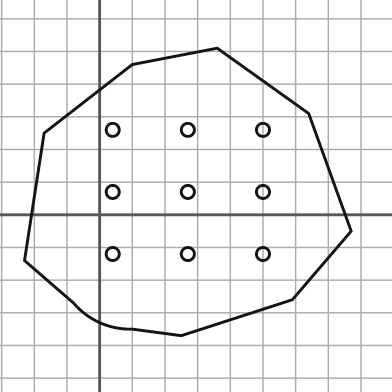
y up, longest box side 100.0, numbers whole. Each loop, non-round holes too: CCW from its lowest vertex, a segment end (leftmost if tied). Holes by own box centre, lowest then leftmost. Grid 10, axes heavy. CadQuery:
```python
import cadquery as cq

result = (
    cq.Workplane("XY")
    .moveTo(25.0, -37.0)
    .lineTo(59.0, -26.0)
    .lineTo(77.0, -5.0)
    .lineTo(64.0, 31.0)
    .lineTo(36.0, 51.0)
    .lineTo(10.0, 46.0)
    .lineTo(-17.0, 25.0)
    .lineTo(-23.0, -14.0)
    .lineTo(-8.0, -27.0)
    .threePointArc((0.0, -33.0), (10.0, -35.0))
    .close()
    .moveTo(4.0, -12.0)
    .circle(2.0)
    .moveTo(27.0, -12.0)
    .circle(2.0)
    .moveTo(50.0, -12.0)
    .circle(2.0)
    .moveTo(4.0, 7.0)
    .circle(2.0)
    .moveTo(27.0, 7.0)
    .circle(2.0)
    .moveTo(50.0, 7.0)
    .circle(2.0)
    .moveTo(4.0, 26.0)
    .circle(2.0)
    .moveTo(27.0, 26.0)
    .circle(2.0)
    .moveTo(50.0, 26.0)
    .circle(2.0)
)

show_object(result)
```